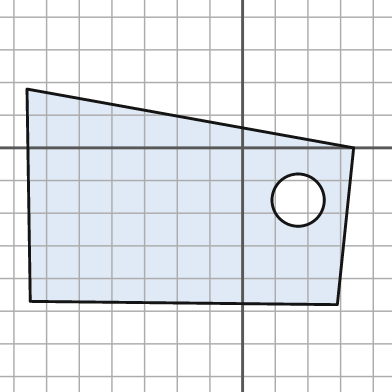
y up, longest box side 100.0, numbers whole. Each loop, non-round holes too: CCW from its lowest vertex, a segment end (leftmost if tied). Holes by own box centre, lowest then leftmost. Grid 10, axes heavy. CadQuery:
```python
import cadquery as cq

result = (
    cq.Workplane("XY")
    .moveTo(29.0, -48.0)
    .lineTo(34.0, 0.0)
    .lineTo(-66.0, 18.0)
    .lineTo(-65.0, -47.0)
    .close()
    .moveTo(17.0, -16.0)
    .circle(8.0)
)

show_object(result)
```